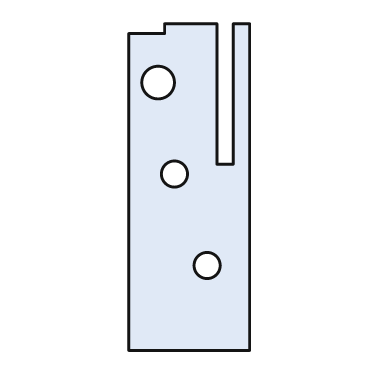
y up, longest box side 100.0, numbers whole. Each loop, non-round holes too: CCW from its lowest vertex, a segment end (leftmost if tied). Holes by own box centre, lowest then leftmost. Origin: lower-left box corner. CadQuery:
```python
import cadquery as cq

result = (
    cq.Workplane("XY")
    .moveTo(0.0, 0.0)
    .lineTo(37.0, 0.0)
    .lineTo(37.0, 100.0)
    .lineTo(32.0, 100.0)
    .lineTo(32.0, 57.0)
    .lineTo(27.0, 57.0)
    .lineTo(27.0, 100.0)
    .lineTo(11.0, 100.0)
    .lineTo(11.0, 97.0)
    .lineTo(0.0, 97.0)
    .close()
    .moveTo(24.0, 26.0)
    .circle(4.0)
    .moveTo(14.0, 54.0)
    .circle(4.0)
    .moveTo(9.0, 82.0)
    .circle(5.0)
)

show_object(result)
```